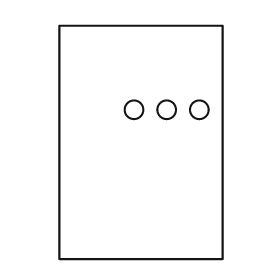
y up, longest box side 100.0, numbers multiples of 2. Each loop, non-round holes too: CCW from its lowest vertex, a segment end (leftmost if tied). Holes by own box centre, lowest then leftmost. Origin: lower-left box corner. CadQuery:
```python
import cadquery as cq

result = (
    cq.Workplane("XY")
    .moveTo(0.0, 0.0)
    .lineTo(70.0, 0.0)
    .lineTo(70.0, 100.0)
    .lineTo(0.0, 100.0)
    .close()
    .moveTo(32.0, 64.0)
    .circle(4.0)
    .moveTo(46.0, 64.0)
    .circle(4.0)
    .moveTo(60.0, 64.0)
    .circle(4.0)
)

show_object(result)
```